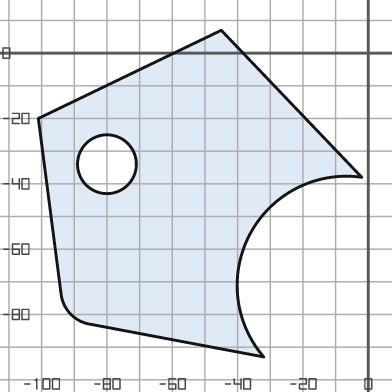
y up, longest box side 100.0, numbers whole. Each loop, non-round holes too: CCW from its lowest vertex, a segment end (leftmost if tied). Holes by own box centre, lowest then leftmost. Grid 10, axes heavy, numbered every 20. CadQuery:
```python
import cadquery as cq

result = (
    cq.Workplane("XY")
    .moveTo(-32.0, -93.0)
    .threePointArc((-36.0, -55.0), (-2.0, -38.0))
    .lineTo(-45.0, 7.0)
    .lineTo(-101.0, -20.0)
    .lineTo(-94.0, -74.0)
    .threePointArc((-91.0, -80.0), (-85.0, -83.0))
    .close()
    .moveTo(-80.0, -34.0)
    .circle(9.0)
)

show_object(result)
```